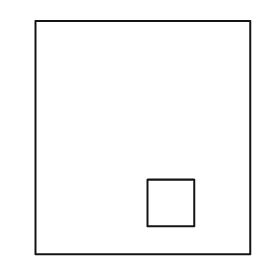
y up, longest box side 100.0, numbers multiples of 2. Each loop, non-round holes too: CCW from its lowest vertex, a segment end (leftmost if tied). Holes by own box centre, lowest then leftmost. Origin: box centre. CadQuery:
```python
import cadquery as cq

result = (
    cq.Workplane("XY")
    .moveTo(-46.0, -50.0)
    .lineTo(46.0, -50.0)
    .lineTo(46.0, 50.0)
    .lineTo(-46.0, 50.0)
    .close()
    .moveTo(2.0, -38.0)
    .lineTo(22.0, -38.0)
    .lineTo(22.0, -18.0)
    .lineTo(2.0, -18.0)
    .close()
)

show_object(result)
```